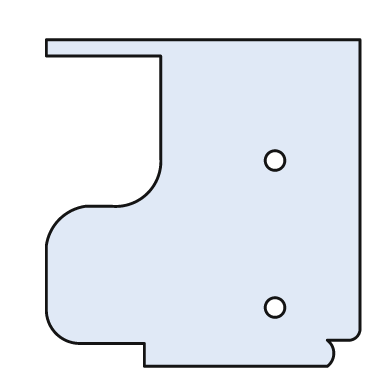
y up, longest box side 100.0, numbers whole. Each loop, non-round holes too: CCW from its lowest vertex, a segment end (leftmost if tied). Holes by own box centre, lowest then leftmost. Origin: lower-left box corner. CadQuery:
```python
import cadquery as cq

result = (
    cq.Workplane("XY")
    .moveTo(30.0, 0.0)
    .lineTo(86.0, 0.0)
    .threePointArc((88.0, 4.0), (86.0, 8.0))
    .lineTo(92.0, 8.0)
    .threePointArc((95.0, 9.0), (96.0, 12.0))
    .lineTo(96.0, 100.0)
    .lineTo(0.0, 100.0)
    .lineTo(0.0, 95.0)
    .lineTo(35.0, 95.0)
    .lineTo(35.0, 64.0)
    .threePointArc((31.0, 53.0), (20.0, 49.0))
    .lineTo(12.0, 49.0)
    .threePointArc((4.0, 45.0), (0.0, 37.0))
    .lineTo(0.0, 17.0)
    .threePointArc((3.0, 10.0), (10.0, 7.0))
    .lineTo(30.0, 7.0)
    .close()
    .moveTo(70.0, 18.0)
    .circle(3.0)
    .moveTo(70.0, 63.0)
    .circle(3.0)
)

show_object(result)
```